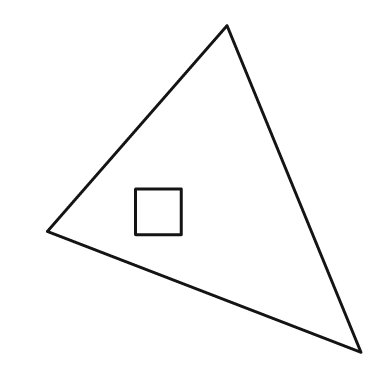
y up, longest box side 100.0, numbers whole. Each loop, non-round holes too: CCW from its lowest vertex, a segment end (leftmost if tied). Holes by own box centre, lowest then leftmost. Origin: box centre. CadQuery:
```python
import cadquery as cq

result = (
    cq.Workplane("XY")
    .moveTo(48.0, -50.0)
    .lineTo(7.0, 50.0)
    .lineTo(-48.0, -13.0)
    .close()
    .moveTo(-21.0, -14.0)
    .lineTo(-7.0, -14.0)
    .lineTo(-7.0, 0.0)
    .lineTo(-21.0, 0.0)
    .close()
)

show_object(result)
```